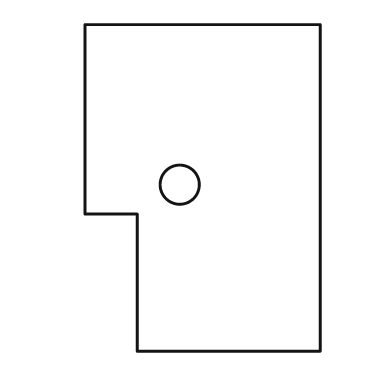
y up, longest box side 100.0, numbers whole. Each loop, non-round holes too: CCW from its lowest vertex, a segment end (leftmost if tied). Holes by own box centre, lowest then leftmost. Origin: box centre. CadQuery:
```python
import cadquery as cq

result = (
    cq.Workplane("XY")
    .moveTo(-20.0, -50.0)
    .lineTo(36.0, -50.0)
    .lineTo(36.0, 50.0)
    .lineTo(-36.0, 50.0)
    .lineTo(-36.0, -8.0)
    .lineTo(-20.0, -8.0)
    .close()
    .moveTo(-7.0, 1.0)
    .circle(6.0)
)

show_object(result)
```